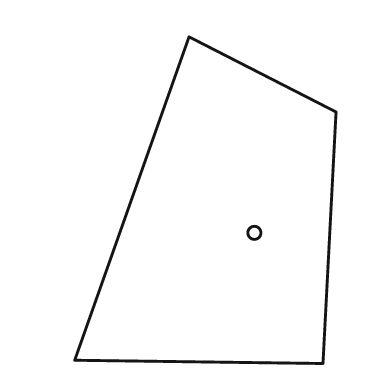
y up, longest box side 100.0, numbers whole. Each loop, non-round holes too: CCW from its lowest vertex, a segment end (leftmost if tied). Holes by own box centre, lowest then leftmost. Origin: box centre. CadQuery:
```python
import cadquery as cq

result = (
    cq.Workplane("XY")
    .moveTo(36.0, -50.0)
    .lineTo(40.0, 27.0)
    .lineTo(-5.0, 50.0)
    .lineTo(-40.0, -49.0)
    .close()
    .moveTo(15.0, -10.0)
    .circle(2.0)
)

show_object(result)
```